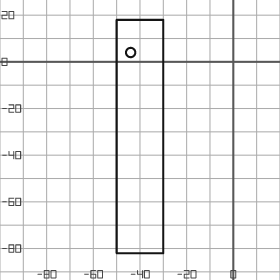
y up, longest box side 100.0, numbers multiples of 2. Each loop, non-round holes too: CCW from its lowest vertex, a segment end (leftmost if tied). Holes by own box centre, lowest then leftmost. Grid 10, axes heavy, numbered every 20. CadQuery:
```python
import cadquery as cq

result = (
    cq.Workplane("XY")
    .moveTo(-50.0, -82.0)
    .lineTo(-30.0, -82.0)
    .lineTo(-30.0, 18.0)
    .lineTo(-50.0, 18.0)
    .close()
    .moveTo(-44.0, 4.0)
    .circle(2.0)
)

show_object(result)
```